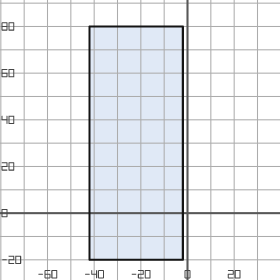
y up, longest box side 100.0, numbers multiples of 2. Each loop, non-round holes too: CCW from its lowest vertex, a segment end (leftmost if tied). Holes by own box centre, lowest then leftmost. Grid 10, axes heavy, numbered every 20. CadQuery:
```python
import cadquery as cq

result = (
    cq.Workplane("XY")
    .moveTo(-42.0, -20.0)
    .lineTo(-2.0, -20.0)
    .lineTo(-2.0, 80.0)
    .lineTo(-42.0, 80.0)
    .close()
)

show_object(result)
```